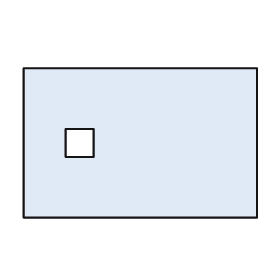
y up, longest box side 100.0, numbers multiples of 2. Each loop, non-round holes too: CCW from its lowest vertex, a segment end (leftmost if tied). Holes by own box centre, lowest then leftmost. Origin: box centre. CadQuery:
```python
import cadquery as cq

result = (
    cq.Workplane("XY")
    .moveTo(-50.0, -32.0)
    .lineTo(50.0, -32.0)
    .lineTo(50.0, 32.0)
    .lineTo(-50.0, 32.0)
    .close()
    .moveTo(-32.0, -6.0)
    .lineTo(-20.0, -6.0)
    .lineTo(-20.0, 6.0)
    .lineTo(-32.0, 6.0)
    .close()
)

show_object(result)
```